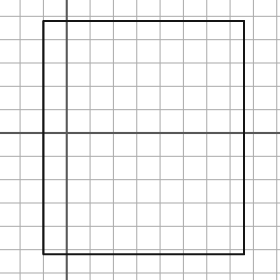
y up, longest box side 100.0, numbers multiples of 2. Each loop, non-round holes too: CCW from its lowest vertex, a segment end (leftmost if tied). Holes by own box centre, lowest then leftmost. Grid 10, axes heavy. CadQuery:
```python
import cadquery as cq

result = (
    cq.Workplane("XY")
    .moveTo(-10.0, -52.0)
    .lineTo(76.0, -52.0)
    .lineTo(76.0, 48.0)
    .lineTo(-10.0, 48.0)
    .close()
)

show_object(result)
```